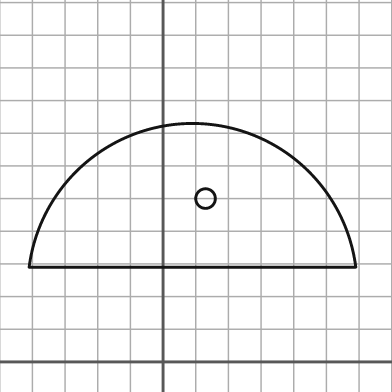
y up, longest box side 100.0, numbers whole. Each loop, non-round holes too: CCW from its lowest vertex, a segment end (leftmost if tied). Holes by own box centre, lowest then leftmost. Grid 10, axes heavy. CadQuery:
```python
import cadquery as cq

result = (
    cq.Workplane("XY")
    .moveTo(-41.0, 29.0)
    .lineTo(59.0, 29.0)
    .threePointArc((9.0, 73.0), (-41.0, 29.0))
    .close()
    .moveTo(13.0, 50.0)
    .circle(3.0)
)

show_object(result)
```